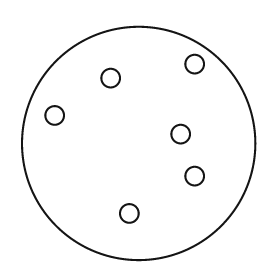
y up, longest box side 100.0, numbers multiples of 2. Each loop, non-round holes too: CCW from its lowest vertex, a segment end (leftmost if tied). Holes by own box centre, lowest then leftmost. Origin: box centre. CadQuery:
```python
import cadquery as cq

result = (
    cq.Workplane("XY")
    .moveTo(0.0, 0.0)
    .circle(50.0)
    .moveTo(-4.0, -30.0)
    .circle(4.0)
    .moveTo(24.0, -14.0)
    .circle(4.0)
    .moveTo(18.0, 4.0)
    .circle(4.0)
    .moveTo(-36.0, 12.0)
    .circle(4.0)
    .moveTo(-12.0, 28.0)
    .circle(4.0)
    .moveTo(24.0, 34.0)
    .circle(4.0)
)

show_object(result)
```